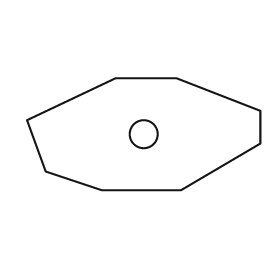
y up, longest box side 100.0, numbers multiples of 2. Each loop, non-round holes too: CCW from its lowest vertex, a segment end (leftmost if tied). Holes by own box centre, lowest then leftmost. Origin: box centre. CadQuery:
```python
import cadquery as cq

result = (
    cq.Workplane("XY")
    .moveTo(-18.0, -24.0)
    .lineTo(16.0, -24.0)
    .lineTo(50.0, -4.0)
    .lineTo(50.0, 10.0)
    .lineTo(14.0, 24.0)
    .lineTo(-12.0, 24.0)
    .lineTo(-50.0, 6.0)
    .lineTo(-42.0, -16.0)
    .close()
    .moveTo(0.0, 0.0)
    .circle(6.0)
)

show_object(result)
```